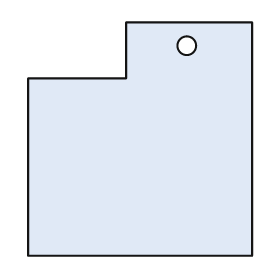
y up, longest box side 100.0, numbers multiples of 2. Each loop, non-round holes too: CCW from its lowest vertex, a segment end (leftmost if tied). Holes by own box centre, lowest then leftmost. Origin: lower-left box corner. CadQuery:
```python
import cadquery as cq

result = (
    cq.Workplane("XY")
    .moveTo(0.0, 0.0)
    .lineTo(96.0, 0.0)
    .lineTo(96.0, 100.0)
    .lineTo(42.0, 100.0)
    .lineTo(42.0, 76.0)
    .lineTo(0.0, 76.0)
    .close()
    .moveTo(68.0, 90.0)
    .circle(4.0)
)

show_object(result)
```